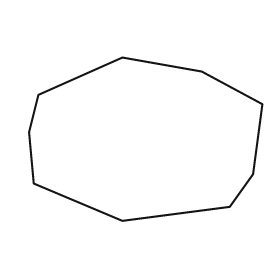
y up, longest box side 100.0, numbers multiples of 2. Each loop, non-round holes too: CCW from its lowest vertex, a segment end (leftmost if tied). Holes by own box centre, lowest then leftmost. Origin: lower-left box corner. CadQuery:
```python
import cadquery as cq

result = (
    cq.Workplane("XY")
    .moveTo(40.0, 0.0)
    .lineTo(86.0, 6.0)
    .lineTo(96.0, 20.0)
    .lineTo(100.0, 50.0)
    .lineTo(74.0, 64.0)
    .lineTo(40.0, 70.0)
    .lineTo(4.0, 54.0)
    .lineTo(0.0, 38.0)
    .lineTo(2.0, 16.0)
    .close()
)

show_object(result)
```